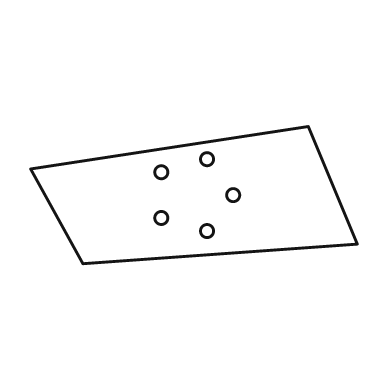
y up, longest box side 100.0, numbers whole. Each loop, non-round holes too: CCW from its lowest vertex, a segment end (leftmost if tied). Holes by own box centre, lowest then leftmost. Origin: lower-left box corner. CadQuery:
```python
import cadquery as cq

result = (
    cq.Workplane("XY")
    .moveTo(16.0, 0.0)
    .lineTo(100.0, 6.0)
    .lineTo(85.0, 42.0)
    .lineTo(0.0, 29.0)
    .close()
    .moveTo(54.0, 10.0)
    .circle(2.0)
    .moveTo(40.0, 14.0)
    .circle(2.0)
    .moveTo(62.0, 21.0)
    .circle(2.0)
    .moveTo(40.0, 28.0)
    .circle(2.0)
    .moveTo(54.0, 32.0)
    .circle(2.0)
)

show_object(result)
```